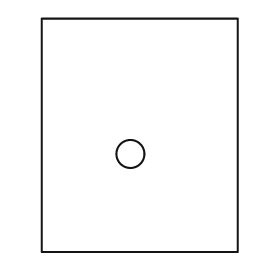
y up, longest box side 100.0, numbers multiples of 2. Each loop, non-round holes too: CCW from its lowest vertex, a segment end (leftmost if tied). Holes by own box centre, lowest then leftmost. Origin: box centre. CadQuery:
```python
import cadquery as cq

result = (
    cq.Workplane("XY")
    .moveTo(-42.0, -50.0)
    .lineTo(42.0, -50.0)
    .lineTo(42.0, 50.0)
    .lineTo(-42.0, 50.0)
    .close()
    .moveTo(-4.0, -8.0)
    .circle(6.0)
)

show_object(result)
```